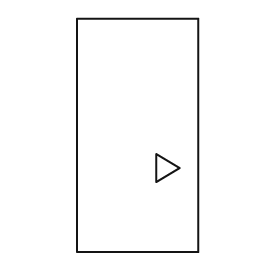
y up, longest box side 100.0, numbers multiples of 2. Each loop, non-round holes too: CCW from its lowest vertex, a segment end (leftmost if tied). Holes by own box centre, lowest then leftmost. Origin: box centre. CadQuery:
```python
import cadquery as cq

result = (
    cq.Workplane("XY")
    .moveTo(-26.0, -50.0)
    .lineTo(26.0, -50.0)
    .lineTo(26.0, 50.0)
    .lineTo(-26.0, 50.0)
    .close()
    .moveTo(8.0, -20.0)
    .lineTo(18.0, -14.0)
    .lineTo(8.0, -8.0)
    .close()
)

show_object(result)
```